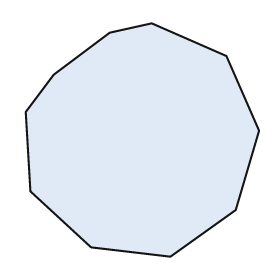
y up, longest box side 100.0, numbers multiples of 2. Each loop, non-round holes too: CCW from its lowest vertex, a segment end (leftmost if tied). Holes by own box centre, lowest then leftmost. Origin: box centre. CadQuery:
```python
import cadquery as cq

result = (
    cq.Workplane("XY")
    .moveTo(12.0, -50.0)
    .lineTo(40.0, -30.0)
    .lineTo(50.0, 4.0)
    .lineTo(36.0, 36.0)
    .lineTo(4.0, 50.0)
    .lineTo(-14.0, 46.0)
    .lineTo(-38.0, 28.0)
    .lineTo(-50.0, 12.0)
    .lineTo(-48.0, -22.0)
    .lineTo(-22.0, -46.0)
    .close()
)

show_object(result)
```